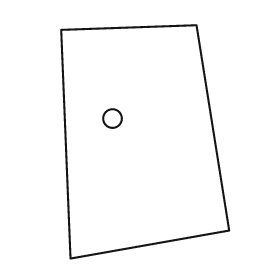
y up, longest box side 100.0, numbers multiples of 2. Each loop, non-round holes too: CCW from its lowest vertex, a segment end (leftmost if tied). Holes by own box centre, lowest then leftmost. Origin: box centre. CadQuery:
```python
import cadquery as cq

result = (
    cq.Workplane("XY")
    .moveTo(-32.0, -50.0)
    .lineTo(36.0, -38.0)
    .lineTo(22.0, 50.0)
    .lineTo(-36.0, 48.0)
    .close()
    .moveTo(-14.0, 10.0)
    .circle(4.0)
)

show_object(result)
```